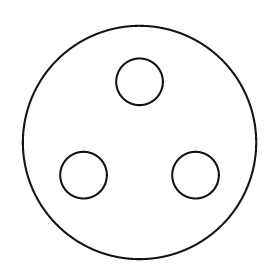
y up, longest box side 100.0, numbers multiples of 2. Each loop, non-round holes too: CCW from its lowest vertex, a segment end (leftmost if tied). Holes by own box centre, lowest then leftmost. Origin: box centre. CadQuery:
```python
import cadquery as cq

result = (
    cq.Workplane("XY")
    .moveTo(0.0, 0.0)
    .circle(50.0)
    .moveTo(-24.0, -14.0)
    .circle(10.0)
    .moveTo(24.0, -14.0)
    .circle(10.0)
    .moveTo(0.0, 26.0)
    .circle(10.0)
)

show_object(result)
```